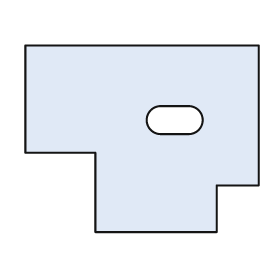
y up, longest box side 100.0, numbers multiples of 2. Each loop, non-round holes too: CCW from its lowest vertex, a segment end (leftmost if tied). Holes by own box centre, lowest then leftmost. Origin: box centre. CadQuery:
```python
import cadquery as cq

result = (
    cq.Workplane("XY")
    .moveTo(-20.0, -40.0)
    .lineTo(32.0, -40.0)
    .lineTo(32.0, -20.0)
    .lineTo(50.0, -20.0)
    .lineTo(50.0, 40.0)
    .lineTo(-50.0, 40.0)
    .lineTo(-50.0, -6.0)
    .lineTo(-20.0, -6.0)
    .close()
    .moveTo(8.0, 2.0)
    .lineTo(20.0, 2.0)
    .threePointArc((26.0, 8.0), (20.0, 14.0))
    .lineTo(8.0, 14.0)
    .threePointArc((2.0, 8.0), (8.0, 2.0))
    .close()
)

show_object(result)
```